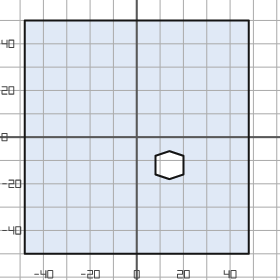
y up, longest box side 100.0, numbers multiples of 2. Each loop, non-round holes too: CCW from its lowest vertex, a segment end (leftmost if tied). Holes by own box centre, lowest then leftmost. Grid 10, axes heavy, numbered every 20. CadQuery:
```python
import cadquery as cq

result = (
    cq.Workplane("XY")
    .moveTo(-48.0, -50.0)
    .lineTo(48.0, -50.0)
    .lineTo(48.0, 50.0)
    .lineTo(-48.0, 50.0)
    .close()
    .moveTo(14.0, -18.0)
    .lineTo(20.0, -16.0)
    .lineTo(20.0, -8.0)
    .lineTo(14.0, -6.0)
    .lineTo(8.0, -8.0)
    .lineTo(8.0, -16.0)
    .close()
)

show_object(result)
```